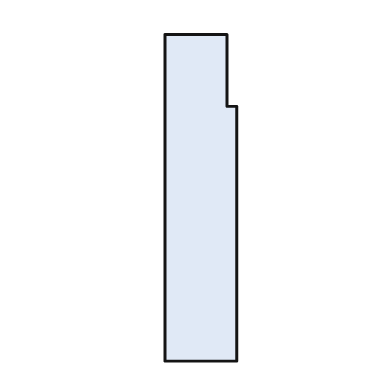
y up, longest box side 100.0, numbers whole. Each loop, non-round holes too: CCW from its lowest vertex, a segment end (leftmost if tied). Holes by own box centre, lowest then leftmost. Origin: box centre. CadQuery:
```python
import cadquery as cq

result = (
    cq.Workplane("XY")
    .moveTo(-11.0, -50.0)
    .lineTo(11.0, -50.0)
    .lineTo(11.0, 28.0)
    .lineTo(8.0, 28.0)
    .lineTo(8.0, 50.0)
    .lineTo(-11.0, 50.0)
    .close()
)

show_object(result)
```